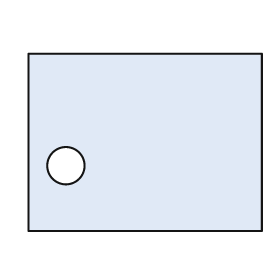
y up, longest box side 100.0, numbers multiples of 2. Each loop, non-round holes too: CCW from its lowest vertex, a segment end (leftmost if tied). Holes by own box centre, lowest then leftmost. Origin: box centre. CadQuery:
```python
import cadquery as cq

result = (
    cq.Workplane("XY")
    .moveTo(-50.0, -38.0)
    .lineTo(50.0, -38.0)
    .lineTo(50.0, 38.0)
    .lineTo(-50.0, 38.0)
    .close()
    .moveTo(-34.0, -10.0)
    .circle(8.0)
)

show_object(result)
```